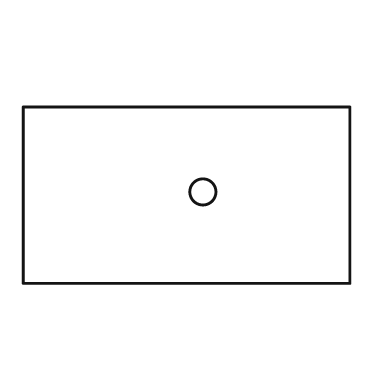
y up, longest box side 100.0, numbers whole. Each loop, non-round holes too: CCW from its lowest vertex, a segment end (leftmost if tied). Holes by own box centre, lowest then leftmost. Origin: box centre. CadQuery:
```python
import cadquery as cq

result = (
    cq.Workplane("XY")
    .moveTo(-50.0, -27.0)
    .lineTo(50.0, -27.0)
    .lineTo(50.0, 27.0)
    .lineTo(-50.0, 27.0)
    .close()
    .moveTo(5.0, 1.0)
    .circle(4.0)
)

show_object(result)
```